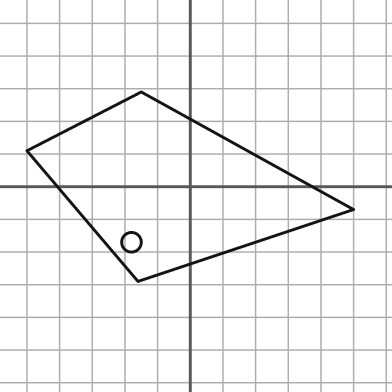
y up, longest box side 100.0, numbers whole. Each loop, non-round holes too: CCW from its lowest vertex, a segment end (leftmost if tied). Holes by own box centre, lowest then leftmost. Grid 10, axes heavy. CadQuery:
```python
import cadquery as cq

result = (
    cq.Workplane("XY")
    .moveTo(-16.0, -29.0)
    .lineTo(50.0, -7.0)
    .lineTo(-15.0, 29.0)
    .lineTo(-50.0, 11.0)
    .close()
    .moveTo(-18.0, -17.0)
    .circle(3.0)
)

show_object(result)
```